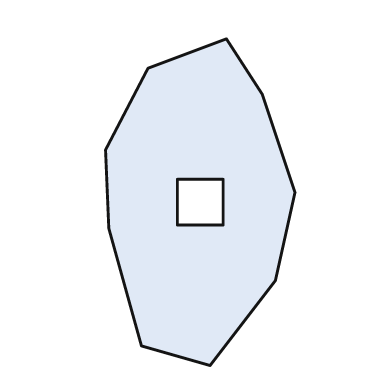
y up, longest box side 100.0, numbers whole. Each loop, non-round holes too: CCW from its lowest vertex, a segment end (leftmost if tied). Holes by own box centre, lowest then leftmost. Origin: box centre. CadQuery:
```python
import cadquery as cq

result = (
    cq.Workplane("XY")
    .moveTo(3.0, -50.0)
    .lineTo(23.0, -24.0)
    .lineTo(29.0, 3.0)
    .lineTo(19.0, 33.0)
    .lineTo(8.0, 50.0)
    .lineTo(-16.0, 41.0)
    .lineTo(-29.0, 16.0)
    .lineTo(-28.0, -8.0)
    .lineTo(-18.0, -44.0)
    .close()
    .moveTo(-7.0, -7.0)
    .lineTo(7.0, -7.0)
    .lineTo(7.0, 7.0)
    .lineTo(-7.0, 7.0)
    .close()
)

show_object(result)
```